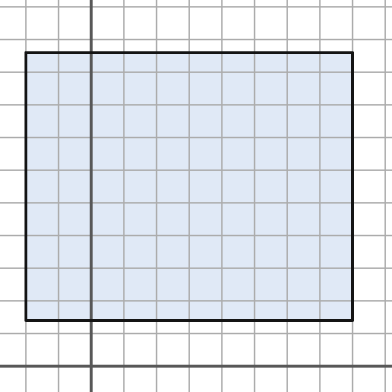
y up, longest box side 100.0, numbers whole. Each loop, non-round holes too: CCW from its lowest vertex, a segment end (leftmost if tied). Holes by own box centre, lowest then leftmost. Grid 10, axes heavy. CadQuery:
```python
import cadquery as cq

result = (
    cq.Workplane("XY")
    .moveTo(-20.0, 14.0)
    .lineTo(80.0, 14.0)
    .lineTo(80.0, 96.0)
    .lineTo(-20.0, 96.0)
    .close()
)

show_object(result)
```